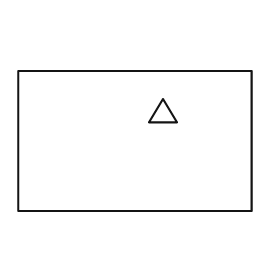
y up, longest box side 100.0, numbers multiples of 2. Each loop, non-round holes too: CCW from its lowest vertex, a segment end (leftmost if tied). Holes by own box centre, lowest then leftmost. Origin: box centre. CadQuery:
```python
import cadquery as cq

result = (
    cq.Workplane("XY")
    .moveTo(-50.0, -30.0)
    .lineTo(50.0, -30.0)
    .lineTo(50.0, 30.0)
    .lineTo(-50.0, 30.0)
    .close()
    .moveTo(6.0, 8.0)
    .lineTo(18.0, 8.0)
    .lineTo(12.0, 18.0)
    .close()
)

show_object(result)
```